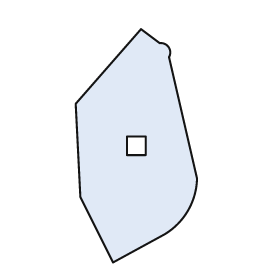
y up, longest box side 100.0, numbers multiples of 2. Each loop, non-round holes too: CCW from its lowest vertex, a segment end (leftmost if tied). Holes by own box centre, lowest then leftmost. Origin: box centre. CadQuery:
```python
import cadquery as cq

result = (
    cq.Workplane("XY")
    .moveTo(-10.0, -50.0)
    .lineTo(12.0, -38.0)
    .threePointArc((22.0, -28.0), (26.0, -14.0))
    .lineTo(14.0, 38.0)
    .threePointArc((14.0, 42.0), (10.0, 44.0))
    .lineTo(2.0, 50.0)
    .lineTo(-26.0, 18.0)
    .lineTo(-24.0, -22.0)
    .close()
    .moveTo(-4.0, -4.0)
    .lineTo(4.0, -4.0)
    .lineTo(4.0, 4.0)
    .lineTo(-4.0, 4.0)
    .close()
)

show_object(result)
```